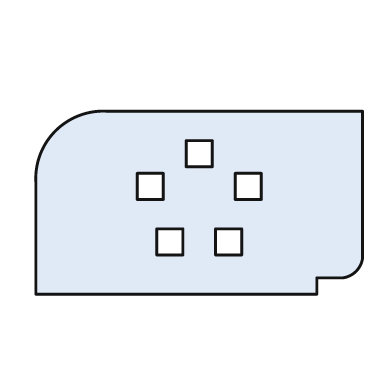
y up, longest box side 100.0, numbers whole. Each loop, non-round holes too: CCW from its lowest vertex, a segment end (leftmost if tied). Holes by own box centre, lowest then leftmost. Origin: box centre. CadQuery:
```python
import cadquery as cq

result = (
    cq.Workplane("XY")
    .moveTo(-50.0, -28.0)
    .lineTo(36.0, -28.0)
    .lineTo(36.0, -23.0)
    .lineTo(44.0, -23.0)
    .threePointArc((48.0, -21.0), (50.0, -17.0))
    .lineTo(50.0, 28.0)
    .lineTo(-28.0, 28.0)
    .threePointArc((-44.0, 22.0), (-50.0, 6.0))
    .close()
    .moveTo(-13.0, -16.0)
    .lineTo(-5.0, -16.0)
    .lineTo(-5.0, -8.0)
    .lineTo(-13.0, -8.0)
    .close()
    .moveTo(5.0, -16.0)
    .lineTo(13.0, -16.0)
    .lineTo(13.0, -8.0)
    .lineTo(5.0, -8.0)
    .close()
    .moveTo(-19.0, 1.0)
    .lineTo(-11.0, 1.0)
    .lineTo(-11.0, 9.0)
    .lineTo(-19.0, 9.0)
    .close()
    .moveTo(11.0, 1.0)
    .lineTo(19.0, 1.0)
    .lineTo(19.0, 9.0)
    .lineTo(11.0, 9.0)
    .close()
    .moveTo(-4.0, 11.0)
    .lineTo(4.0, 11.0)
    .lineTo(4.0, 19.0)
    .lineTo(-4.0, 19.0)
    .close()
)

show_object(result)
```